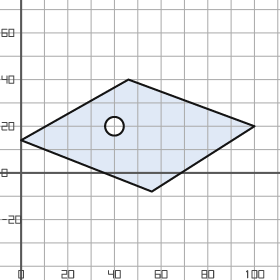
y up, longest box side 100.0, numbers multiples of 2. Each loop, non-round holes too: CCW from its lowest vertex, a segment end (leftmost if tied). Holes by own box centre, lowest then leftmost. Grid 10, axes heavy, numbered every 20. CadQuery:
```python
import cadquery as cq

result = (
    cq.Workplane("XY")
    .moveTo(56.0, -8.0)
    .lineTo(100.0, 20.0)
    .lineTo(46.0, 40.0)
    .lineTo(0.0, 14.0)
    .close()
    .moveTo(40.0, 20.0)
    .circle(4.0)
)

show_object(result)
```